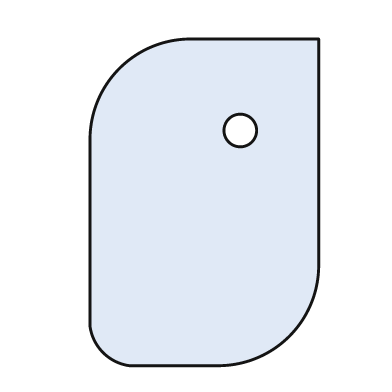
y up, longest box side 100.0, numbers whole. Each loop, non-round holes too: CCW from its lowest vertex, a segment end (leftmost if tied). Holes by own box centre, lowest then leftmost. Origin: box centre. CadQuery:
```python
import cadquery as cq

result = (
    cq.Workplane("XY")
    .moveTo(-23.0, -50.0)
    .lineTo(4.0, -50.0)
    .threePointArc((26.0, -41.0), (35.0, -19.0))
    .lineTo(35.0, 50.0)
    .lineTo(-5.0, 50.0)
    .threePointArc((-26.0, 41.0), (-35.0, 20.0))
    .lineTo(-35.0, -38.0)
    .threePointArc((-31.0, -46.0), (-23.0, -50.0))
    .close()
    .moveTo(11.0, 22.0)
    .circle(5.0)
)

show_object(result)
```